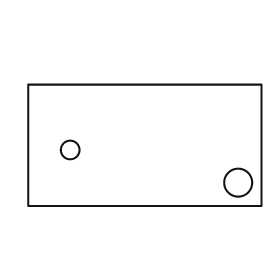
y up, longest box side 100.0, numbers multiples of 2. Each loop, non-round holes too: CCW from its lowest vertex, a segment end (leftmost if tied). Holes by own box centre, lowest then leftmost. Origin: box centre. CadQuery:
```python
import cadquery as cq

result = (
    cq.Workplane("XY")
    .moveTo(-50.0, -26.0)
    .lineTo(50.0, -26.0)
    .lineTo(50.0, 26.0)
    .lineTo(-50.0, 26.0)
    .close()
    .moveTo(40.0, -16.0)
    .circle(6.0)
    .moveTo(-32.0, -2.0)
    .circle(4.0)
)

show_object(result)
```